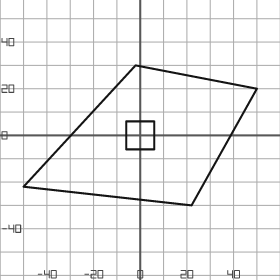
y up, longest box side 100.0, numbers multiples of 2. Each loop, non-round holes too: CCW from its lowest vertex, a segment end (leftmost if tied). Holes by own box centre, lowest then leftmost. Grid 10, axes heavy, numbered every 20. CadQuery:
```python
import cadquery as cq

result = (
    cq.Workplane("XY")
    .moveTo(22.0, -30.0)
    .lineTo(50.0, 20.0)
    .lineTo(-2.0, 30.0)
    .lineTo(-50.0, -22.0)
    .close()
    .moveTo(-6.0, -6.0)
    .lineTo(6.0, -6.0)
    .lineTo(6.0, 6.0)
    .lineTo(-6.0, 6.0)
    .close()
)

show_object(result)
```